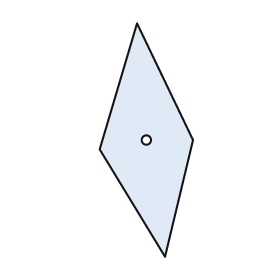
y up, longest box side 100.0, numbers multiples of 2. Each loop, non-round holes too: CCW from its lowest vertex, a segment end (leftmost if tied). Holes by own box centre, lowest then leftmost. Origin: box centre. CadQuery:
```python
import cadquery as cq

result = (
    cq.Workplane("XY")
    .moveTo(8.0, -50.0)
    .lineTo(20.0, 0.0)
    .lineTo(-4.0, 50.0)
    .lineTo(-20.0, -4.0)
    .close()
    .moveTo(0.0, 0.0)
    .circle(2.0)
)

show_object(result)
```